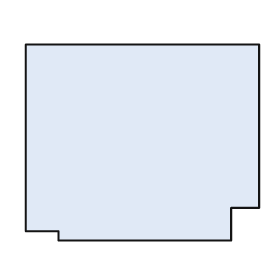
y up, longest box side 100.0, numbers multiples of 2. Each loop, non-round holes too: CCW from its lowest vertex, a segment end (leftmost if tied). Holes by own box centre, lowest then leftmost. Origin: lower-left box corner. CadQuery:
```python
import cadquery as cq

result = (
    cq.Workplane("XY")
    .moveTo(14.0, 0.0)
    .lineTo(88.0, 0.0)
    .lineTo(88.0, 14.0)
    .lineTo(100.0, 14.0)
    .lineTo(100.0, 84.0)
    .lineTo(0.0, 84.0)
    .lineTo(0.0, 4.0)
    .lineTo(14.0, 4.0)
    .close()
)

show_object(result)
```